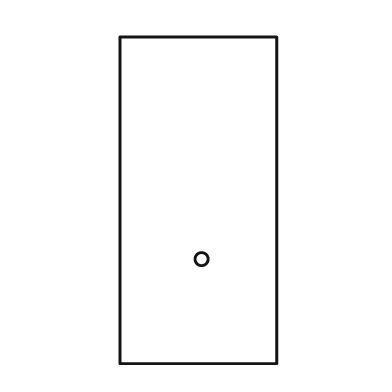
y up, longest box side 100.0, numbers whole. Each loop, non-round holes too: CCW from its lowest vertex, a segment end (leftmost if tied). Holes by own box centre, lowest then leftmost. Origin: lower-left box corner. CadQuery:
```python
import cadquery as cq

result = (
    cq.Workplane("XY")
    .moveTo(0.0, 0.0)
    .lineTo(48.0, 0.0)
    .lineTo(48.0, 100.0)
    .lineTo(0.0, 100.0)
    .close()
    .moveTo(25.0, 32.0)
    .circle(2.0)
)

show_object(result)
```